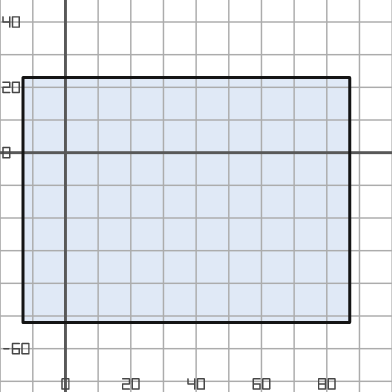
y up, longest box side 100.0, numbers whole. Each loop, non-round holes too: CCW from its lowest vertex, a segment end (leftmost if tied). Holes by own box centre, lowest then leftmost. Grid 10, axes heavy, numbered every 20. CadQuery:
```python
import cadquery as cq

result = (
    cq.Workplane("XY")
    .moveTo(-13.0, -52.0)
    .lineTo(87.0, -52.0)
    .lineTo(87.0, 23.0)
    .lineTo(-13.0, 23.0)
    .close()
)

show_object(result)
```